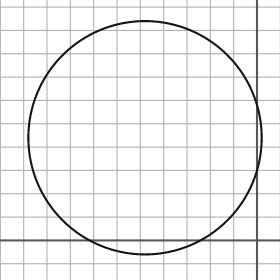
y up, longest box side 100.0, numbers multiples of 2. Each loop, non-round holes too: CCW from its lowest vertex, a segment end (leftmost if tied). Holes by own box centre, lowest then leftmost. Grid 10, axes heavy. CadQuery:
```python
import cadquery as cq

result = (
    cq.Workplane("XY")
    .moveTo(-48.0, 44.0)
    .circle(50.0)
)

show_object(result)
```